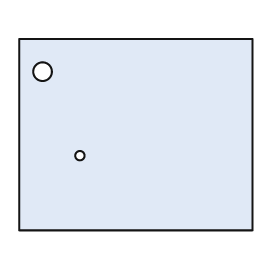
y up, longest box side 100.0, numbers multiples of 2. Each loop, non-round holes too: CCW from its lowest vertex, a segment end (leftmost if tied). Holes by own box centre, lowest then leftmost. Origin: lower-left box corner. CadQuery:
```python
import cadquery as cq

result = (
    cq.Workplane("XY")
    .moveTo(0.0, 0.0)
    .lineTo(100.0, 0.0)
    .lineTo(100.0, 82.0)
    .lineTo(0.0, 82.0)
    .close()
    .moveTo(26.0, 32.0)
    .circle(2.0)
    .moveTo(10.0, 68.0)
    .circle(4.0)
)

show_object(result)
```